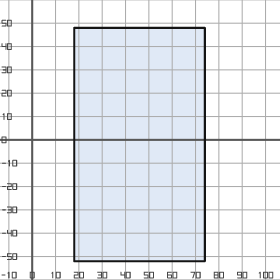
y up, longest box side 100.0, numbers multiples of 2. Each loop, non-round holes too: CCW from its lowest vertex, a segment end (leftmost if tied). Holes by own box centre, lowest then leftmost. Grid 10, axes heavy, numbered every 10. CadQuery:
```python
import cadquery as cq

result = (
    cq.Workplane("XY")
    .moveTo(18.0, -52.0)
    .lineTo(74.0, -52.0)
    .lineTo(74.0, 48.0)
    .lineTo(18.0, 48.0)
    .close()
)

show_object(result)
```